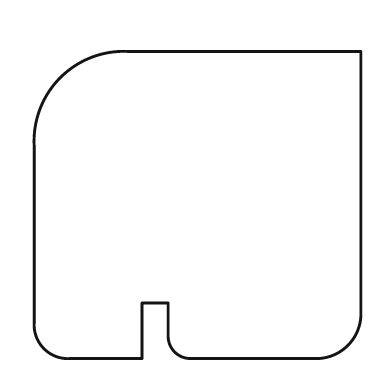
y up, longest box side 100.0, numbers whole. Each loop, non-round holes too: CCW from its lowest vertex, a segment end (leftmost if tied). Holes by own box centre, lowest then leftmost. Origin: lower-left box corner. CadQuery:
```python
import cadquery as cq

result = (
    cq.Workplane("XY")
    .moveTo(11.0, 0.0)
    .lineTo(33.0, 0.0)
    .lineTo(33.0, 17.0)
    .lineTo(41.0, 17.0)
    .lineTo(41.0, 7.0)
    .threePointArc((43.0, 2.0), (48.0, 0.0))
    .lineTo(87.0, 0.0)
    .threePointArc((96.0, 4.0), (100.0, 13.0))
    .lineTo(100.0, 94.0)
    .lineTo(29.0, 94.0)
    .threePointArc((8.0, 86.0), (0.0, 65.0))
    .lineTo(0.0, 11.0)
    .threePointArc((3.0, 3.0), (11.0, 0.0))
    .close()
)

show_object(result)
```